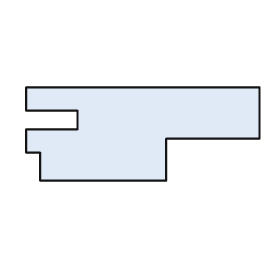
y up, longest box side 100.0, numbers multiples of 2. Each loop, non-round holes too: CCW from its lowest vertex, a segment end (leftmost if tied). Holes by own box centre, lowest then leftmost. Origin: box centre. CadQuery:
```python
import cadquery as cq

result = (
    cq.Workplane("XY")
    .moveTo(-44.0, -20.0)
    .lineTo(10.0, -20.0)
    .lineTo(10.0, -2.0)
    .lineTo(50.0, -2.0)
    .lineTo(50.0, 20.0)
    .lineTo(-50.0, 20.0)
    .lineTo(-50.0, 10.0)
    .lineTo(-28.0, 10.0)
    .lineTo(-28.0, 2.0)
    .lineTo(-50.0, 2.0)
    .lineTo(-50.0, -8.0)
    .lineTo(-44.0, -8.0)
    .close()
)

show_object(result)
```